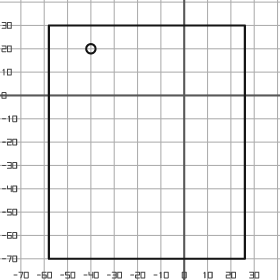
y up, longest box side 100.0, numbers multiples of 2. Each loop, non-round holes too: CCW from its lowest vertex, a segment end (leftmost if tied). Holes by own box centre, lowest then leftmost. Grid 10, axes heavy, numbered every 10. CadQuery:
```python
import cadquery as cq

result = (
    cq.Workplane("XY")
    .moveTo(-58.0, -70.0)
    .lineTo(26.0, -70.0)
    .lineTo(26.0, 30.0)
    .lineTo(-58.0, 30.0)
    .close()
    .moveTo(-40.0, 20.0)
    .circle(2.0)
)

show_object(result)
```